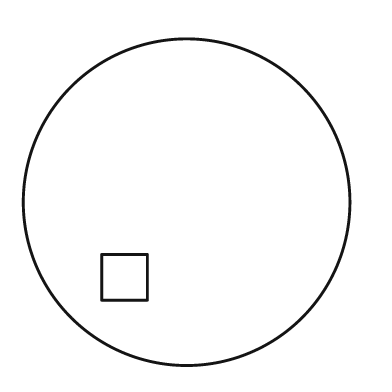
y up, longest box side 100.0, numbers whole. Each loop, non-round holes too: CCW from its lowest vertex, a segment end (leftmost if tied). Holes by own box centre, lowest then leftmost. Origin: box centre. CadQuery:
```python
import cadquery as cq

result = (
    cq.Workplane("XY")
    .moveTo(0.0, 0.0)
    .circle(50.0)
    .moveTo(-26.0, -30.0)
    .lineTo(-12.0, -30.0)
    .lineTo(-12.0, -16.0)
    .lineTo(-26.0, -16.0)
    .close()
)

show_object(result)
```